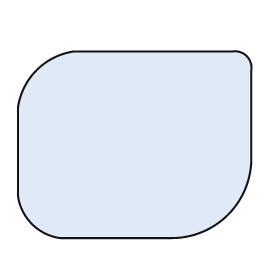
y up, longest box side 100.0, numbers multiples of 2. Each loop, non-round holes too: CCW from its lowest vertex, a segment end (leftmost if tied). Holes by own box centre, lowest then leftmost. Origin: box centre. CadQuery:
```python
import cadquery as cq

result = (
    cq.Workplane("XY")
    .moveTo(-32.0, -40.0)
    .lineTo(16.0, -40.0)
    .threePointArc((40.0, -30.0), (50.0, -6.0))
    .lineTo(50.0, 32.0)
    .threePointArc((48.0, 38.0), (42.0, 40.0))
    .lineTo(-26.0, 40.0)
    .threePointArc((-42.0, 32.0), (-50.0, 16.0))
    .lineTo(-50.0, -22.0)
    .threePointArc((-44.0, -34.0), (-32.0, -40.0))
    .close()
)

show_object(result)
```